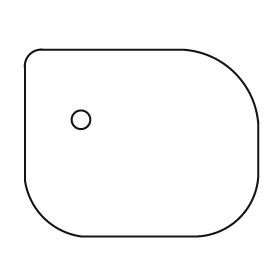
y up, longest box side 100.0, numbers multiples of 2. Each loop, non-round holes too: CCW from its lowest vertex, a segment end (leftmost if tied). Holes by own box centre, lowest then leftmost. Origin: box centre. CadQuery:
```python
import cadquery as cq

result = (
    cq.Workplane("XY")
    .moveTo(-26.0, -40.0)
    .lineTo(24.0, -40.0)
    .threePointArc((42.0, -32.0), (50.0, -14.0))
    .lineTo(50.0, 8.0)
    .threePointArc((40.0, 30.0), (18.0, 40.0))
    .lineTo(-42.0, 40.0)
    .threePointArc((-48.0, 38.0), (-50.0, 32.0))
    .lineTo(-50.0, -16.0)
    .threePointArc((-42.0, -32.0), (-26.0, -40.0))
    .close()
    .moveTo(-26.0, 10.0)
    .circle(4.0)
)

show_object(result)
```